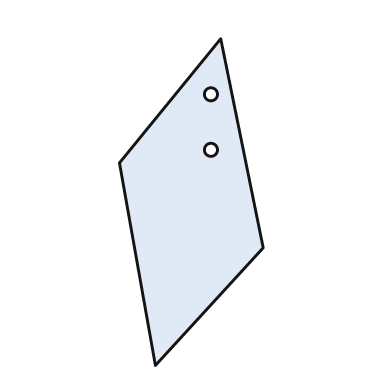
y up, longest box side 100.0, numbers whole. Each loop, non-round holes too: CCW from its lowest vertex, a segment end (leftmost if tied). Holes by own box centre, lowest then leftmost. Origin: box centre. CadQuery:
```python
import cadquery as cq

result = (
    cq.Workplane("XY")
    .moveTo(-11.0, -50.0)
    .lineTo(22.0, -14.0)
    .lineTo(9.0, 50.0)
    .lineTo(-22.0, 12.0)
    .close()
    .moveTo(6.0, 16.0)
    .circle(2.0)
    .moveTo(6.0, 33.0)
    .circle(2.0)
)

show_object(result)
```